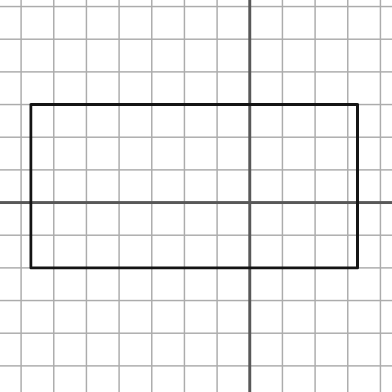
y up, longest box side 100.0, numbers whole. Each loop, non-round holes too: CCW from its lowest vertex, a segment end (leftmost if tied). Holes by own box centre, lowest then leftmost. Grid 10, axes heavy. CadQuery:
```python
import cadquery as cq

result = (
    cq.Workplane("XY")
    .moveTo(-67.0, -20.0)
    .lineTo(33.0, -20.0)
    .lineTo(33.0, 30.0)
    .lineTo(-67.0, 30.0)
    .close()
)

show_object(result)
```